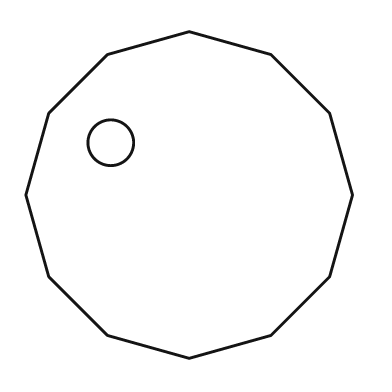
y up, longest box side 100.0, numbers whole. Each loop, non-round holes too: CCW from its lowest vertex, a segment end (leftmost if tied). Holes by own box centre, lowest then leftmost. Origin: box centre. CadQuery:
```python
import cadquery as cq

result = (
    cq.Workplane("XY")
    .moveTo(0.0, -50.0)
    .lineTo(25.0, -43.0)
    .lineTo(43.0, -25.0)
    .lineTo(50.0, 0.0)
    .lineTo(43.0, 25.0)
    .lineTo(25.0, 43.0)
    .lineTo(0.0, 50.0)
    .lineTo(-25.0, 43.0)
    .lineTo(-43.0, 25.0)
    .lineTo(-50.0, 0.0)
    .lineTo(-43.0, -25.0)
    .lineTo(-25.0, -43.0)
    .close()
    .moveTo(-24.0, 16.0)
    .circle(7.0)
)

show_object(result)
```